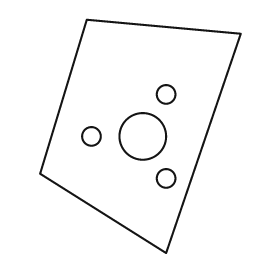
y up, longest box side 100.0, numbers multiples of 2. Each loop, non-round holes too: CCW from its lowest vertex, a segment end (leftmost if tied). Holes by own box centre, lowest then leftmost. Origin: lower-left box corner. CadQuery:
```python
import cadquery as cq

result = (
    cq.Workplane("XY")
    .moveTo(54.0, 0.0)
    .lineTo(86.0, 94.0)
    .lineTo(20.0, 100.0)
    .lineTo(0.0, 34.0)
    .close()
    .moveTo(54.0, 32.0)
    .circle(4.0)
    .moveTo(22.0, 50.0)
    .circle(4.0)
    .moveTo(44.0, 50.0)
    .circle(10.0)
    .moveTo(54.0, 68.0)
    .circle(4.0)
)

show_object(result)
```